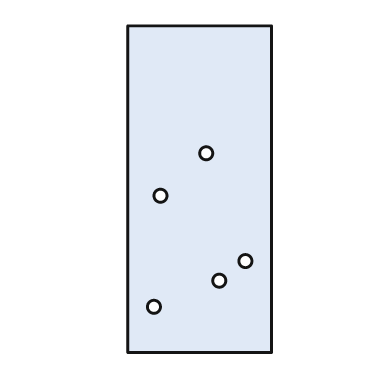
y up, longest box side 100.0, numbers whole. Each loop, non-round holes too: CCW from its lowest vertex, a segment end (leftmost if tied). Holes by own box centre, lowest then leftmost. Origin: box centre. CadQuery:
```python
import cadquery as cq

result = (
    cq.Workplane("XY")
    .moveTo(-22.0, -50.0)
    .lineTo(22.0, -50.0)
    .lineTo(22.0, 50.0)
    .lineTo(-22.0, 50.0)
    .close()
    .moveTo(-14.0, -36.0)
    .circle(2.0)
    .moveTo(6.0, -28.0)
    .circle(2.0)
    .moveTo(14.0, -22.0)
    .circle(2.0)
    .moveTo(-12.0, -2.0)
    .circle(2.0)
    .moveTo(2.0, 11.0)
    .circle(2.0)
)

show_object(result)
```